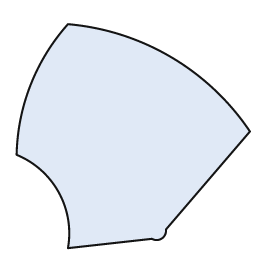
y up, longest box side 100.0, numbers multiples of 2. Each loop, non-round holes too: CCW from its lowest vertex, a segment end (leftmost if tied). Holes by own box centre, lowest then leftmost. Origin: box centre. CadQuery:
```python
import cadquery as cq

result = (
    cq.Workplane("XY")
    .moveTo(-28.0, -48.0)
    .lineTo(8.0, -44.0)
    .threePointArc((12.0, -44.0), (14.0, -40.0))
    .lineTo(50.0, 2.0)
    .threePointArc((16.0, 34.0), (-28.0, 48.0))
    .threePointArc((-44.0, 22.0), (-50.0, -8.0))
    .threePointArc((-32.0, -24.0), (-28.0, -48.0))
    .close()
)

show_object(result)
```